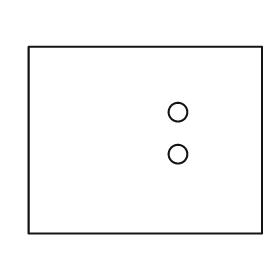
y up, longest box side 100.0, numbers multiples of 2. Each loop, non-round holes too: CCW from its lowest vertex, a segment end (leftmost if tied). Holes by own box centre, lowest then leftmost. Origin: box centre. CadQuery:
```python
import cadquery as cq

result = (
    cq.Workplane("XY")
    .moveTo(-50.0, -40.0)
    .lineTo(50.0, -40.0)
    .lineTo(50.0, 40.0)
    .lineTo(-50.0, 40.0)
    .close()
    .moveTo(14.0, -6.0)
    .circle(4.0)
    .moveTo(14.0, 12.0)
    .circle(4.0)
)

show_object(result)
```